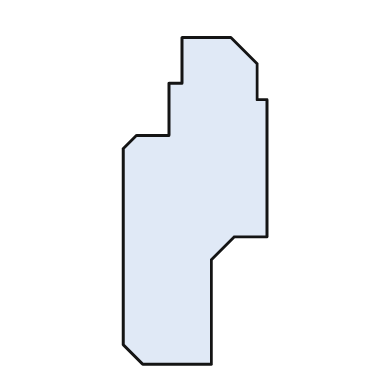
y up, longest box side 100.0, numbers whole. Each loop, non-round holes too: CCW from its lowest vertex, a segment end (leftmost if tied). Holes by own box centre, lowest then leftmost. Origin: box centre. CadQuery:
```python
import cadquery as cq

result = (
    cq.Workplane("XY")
    .moveTo(-16.0, -50.0)
    .lineTo(5.0, -50.0)
    .lineTo(5.0, -18.0)
    .lineTo(12.0, -11.0)
    .lineTo(22.0, -11.0)
    .lineTo(22.0, 31.0)
    .lineTo(19.0, 31.0)
    .lineTo(19.0, 42.0)
    .lineTo(11.0, 50.0)
    .lineTo(-4.0, 50.0)
    .lineTo(-4.0, 36.0)
    .lineTo(-8.0, 36.0)
    .lineTo(-8.0, 20.0)
    .lineTo(-18.0, 20.0)
    .lineTo(-22.0, 16.0)
    .lineTo(-22.0, -44.0)
    .close()
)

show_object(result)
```